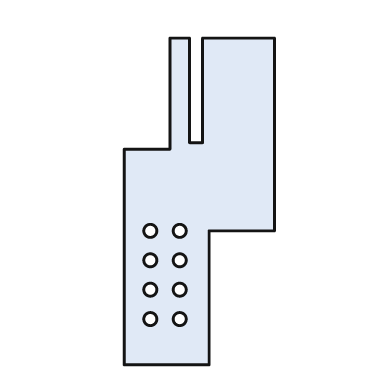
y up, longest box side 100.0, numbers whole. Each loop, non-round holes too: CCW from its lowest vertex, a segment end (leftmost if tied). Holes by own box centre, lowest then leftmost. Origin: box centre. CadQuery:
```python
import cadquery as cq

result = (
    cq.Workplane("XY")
    .moveTo(-23.0, -50.0)
    .lineTo(3.0, -50.0)
    .lineTo(3.0, -9.0)
    .lineTo(23.0, -9.0)
    .lineTo(23.0, 50.0)
    .lineTo(1.0, 50.0)
    .lineTo(1.0, 18.0)
    .lineTo(-3.0, 18.0)
    .lineTo(-3.0, 50.0)
    .lineTo(-9.0, 50.0)
    .lineTo(-9.0, 16.0)
    .lineTo(-23.0, 16.0)
    .close()
    .moveTo(-15.0, -36.0)
    .circle(2.0)
    .moveTo(-6.0, -36.0)
    .circle(2.0)
    .moveTo(-15.0, -27.0)
    .circle(2.0)
    .moveTo(-6.0, -27.0)
    .circle(2.0)
    .moveTo(-15.0, -18.0)
    .circle(2.0)
    .moveTo(-6.0, -18.0)
    .circle(2.0)
    .moveTo(-15.0, -9.0)
    .circle(2.0)
    .moveTo(-6.0, -9.0)
    .circle(2.0)
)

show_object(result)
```